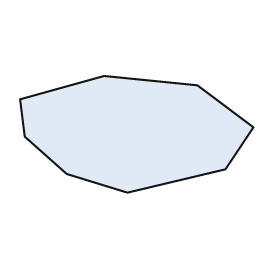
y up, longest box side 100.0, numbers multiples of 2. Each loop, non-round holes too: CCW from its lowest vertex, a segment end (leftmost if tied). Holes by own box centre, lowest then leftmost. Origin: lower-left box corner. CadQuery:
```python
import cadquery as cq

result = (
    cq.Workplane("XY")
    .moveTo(46.0, 0.0)
    .lineTo(88.0, 10.0)
    .lineTo(100.0, 28.0)
    .lineTo(76.0, 46.0)
    .lineTo(36.0, 50.0)
    .lineTo(0.0, 40.0)
    .lineTo(2.0, 24.0)
    .lineTo(20.0, 8.0)
    .close()
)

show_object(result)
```